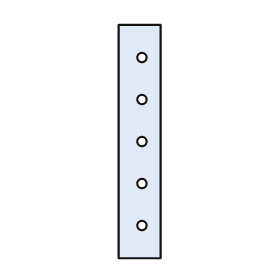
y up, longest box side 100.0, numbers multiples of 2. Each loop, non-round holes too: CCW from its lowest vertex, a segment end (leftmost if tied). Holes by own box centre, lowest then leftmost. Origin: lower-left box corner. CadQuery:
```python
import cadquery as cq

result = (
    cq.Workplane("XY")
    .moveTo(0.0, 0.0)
    .lineTo(18.0, 0.0)
    .lineTo(18.0, 100.0)
    .lineTo(0.0, 100.0)
    .close()
    .moveTo(10.0, 14.0)
    .circle(2.0)
    .moveTo(10.0, 32.0)
    .circle(2.0)
    .moveTo(10.0, 50.0)
    .circle(2.0)
    .moveTo(10.0, 68.0)
    .circle(2.0)
    .moveTo(10.0, 86.0)
    .circle(2.0)
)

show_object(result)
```